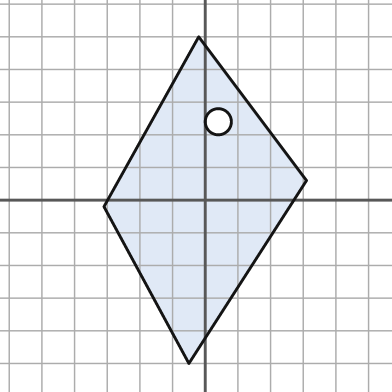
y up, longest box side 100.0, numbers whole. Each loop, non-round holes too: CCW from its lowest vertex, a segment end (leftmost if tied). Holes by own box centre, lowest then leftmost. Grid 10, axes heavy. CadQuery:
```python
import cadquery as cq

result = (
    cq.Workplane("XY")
    .moveTo(-5.0, -50.0)
    .lineTo(31.0, 6.0)
    .lineTo(-2.0, 50.0)
    .lineTo(-31.0, -2.0)
    .close()
    .moveTo(4.0, 24.0)
    .circle(4.0)
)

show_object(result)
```